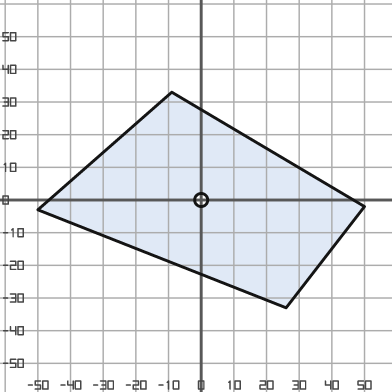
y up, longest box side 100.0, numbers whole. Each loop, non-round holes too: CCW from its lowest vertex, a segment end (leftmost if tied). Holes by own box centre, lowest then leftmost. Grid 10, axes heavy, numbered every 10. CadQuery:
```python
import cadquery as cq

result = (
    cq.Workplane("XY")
    .moveTo(26.0, -33.0)
    .lineTo(50.0, -2.0)
    .lineTo(-9.0, 33.0)
    .lineTo(-50.0, -3.0)
    .close()
    .moveTo(0.0, 0.0)
    .circle(2.0)
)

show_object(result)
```